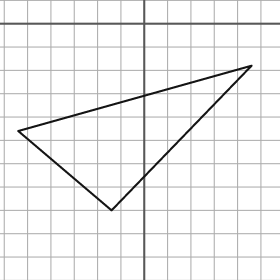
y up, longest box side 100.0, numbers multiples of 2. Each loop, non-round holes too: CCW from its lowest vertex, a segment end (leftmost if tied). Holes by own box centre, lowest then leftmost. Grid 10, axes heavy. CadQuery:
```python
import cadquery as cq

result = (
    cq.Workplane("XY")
    .moveTo(-14.0, -80.0)
    .lineTo(46.0, -18.0)
    .lineTo(-54.0, -46.0)
    .close()
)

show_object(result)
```